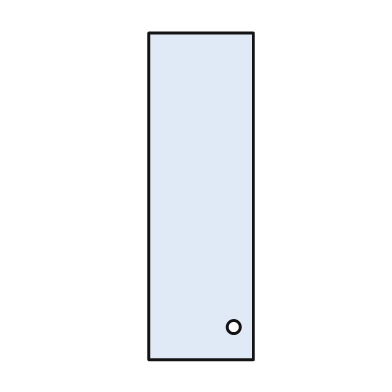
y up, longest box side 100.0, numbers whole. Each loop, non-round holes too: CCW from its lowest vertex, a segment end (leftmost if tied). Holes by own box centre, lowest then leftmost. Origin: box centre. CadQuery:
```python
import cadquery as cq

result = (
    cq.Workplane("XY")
    .moveTo(-16.0, -50.0)
    .lineTo(16.0, -50.0)
    .lineTo(16.0, 50.0)
    .lineTo(-16.0, 50.0)
    .close()
    .moveTo(10.0, -40.0)
    .circle(2.0)
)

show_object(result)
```